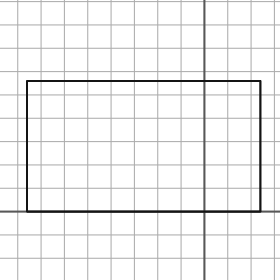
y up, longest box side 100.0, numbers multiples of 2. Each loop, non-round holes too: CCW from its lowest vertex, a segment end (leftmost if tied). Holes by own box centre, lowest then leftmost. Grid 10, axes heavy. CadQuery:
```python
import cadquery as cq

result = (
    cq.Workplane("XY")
    .moveTo(-76.0, 0.0)
    .lineTo(24.0, 0.0)
    .lineTo(24.0, 56.0)
    .lineTo(-76.0, 56.0)
    .close()
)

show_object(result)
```